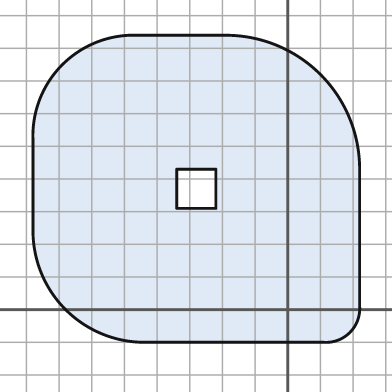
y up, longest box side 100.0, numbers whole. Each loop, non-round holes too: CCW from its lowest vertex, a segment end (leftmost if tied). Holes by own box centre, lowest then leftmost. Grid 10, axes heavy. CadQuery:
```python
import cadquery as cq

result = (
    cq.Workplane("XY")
    .moveTo(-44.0, -10.0)
    .lineTo(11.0, -10.0)
    .threePointArc((19.0, -7.0), (22.0, 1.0))
    .lineTo(22.0, 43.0)
    .threePointArc((10.0, 72.0), (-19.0, 84.0))
    .lineTo(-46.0, 84.0)
    .threePointArc((-69.0, 75.0), (-78.0, 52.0))
    .lineTo(-78.0, 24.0)
    .threePointArc((-68.0, 0.0), (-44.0, -10.0))
    .close()
    .moveTo(-34.0, 31.0)
    .lineTo(-22.0, 31.0)
    .lineTo(-22.0, 43.0)
    .lineTo(-34.0, 43.0)
    .close()
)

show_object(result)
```